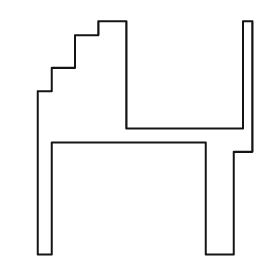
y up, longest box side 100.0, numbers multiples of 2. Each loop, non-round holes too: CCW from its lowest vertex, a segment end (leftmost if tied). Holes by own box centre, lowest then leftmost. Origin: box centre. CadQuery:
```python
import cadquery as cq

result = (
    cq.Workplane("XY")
    .moveTo(-46.0, -50.0)
    .lineTo(-40.0, -50.0)
    .lineTo(-40.0, -2.0)
    .lineTo(26.0, -2.0)
    .lineTo(26.0, -50.0)
    .lineTo(38.0, -50.0)
    .lineTo(38.0, -6.0)
    .lineTo(46.0, -6.0)
    .lineTo(46.0, 50.0)
    .lineTo(42.0, 50.0)
    .lineTo(42.0, 4.0)
    .lineTo(-8.0, 4.0)
    .lineTo(-8.0, 50.0)
    .lineTo(-20.0, 50.0)
    .lineTo(-20.0, 44.0)
    .lineTo(-30.0, 44.0)
    .lineTo(-30.0, 30.0)
    .lineTo(-40.0, 30.0)
    .lineTo(-40.0, 20.0)
    .lineTo(-46.0, 20.0)
    .close()
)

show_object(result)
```